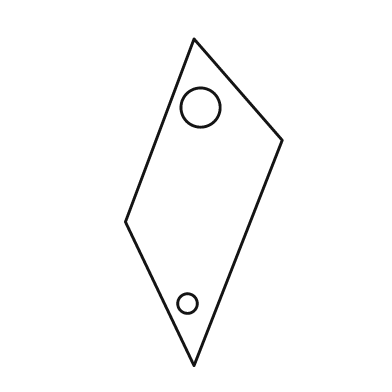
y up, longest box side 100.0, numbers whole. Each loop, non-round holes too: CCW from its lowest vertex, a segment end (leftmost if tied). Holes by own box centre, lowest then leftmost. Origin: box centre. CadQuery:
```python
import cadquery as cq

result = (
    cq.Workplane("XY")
    .moveTo(-3.0, -50.0)
    .lineTo(24.0, 19.0)
    .lineTo(-3.0, 50.0)
    .lineTo(-24.0, -6.0)
    .close()
    .moveTo(-5.0, -31.0)
    .circle(3.0)
    .moveTo(-1.0, 29.0)
    .circle(6.0)
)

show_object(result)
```